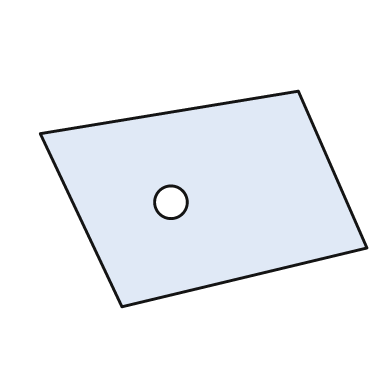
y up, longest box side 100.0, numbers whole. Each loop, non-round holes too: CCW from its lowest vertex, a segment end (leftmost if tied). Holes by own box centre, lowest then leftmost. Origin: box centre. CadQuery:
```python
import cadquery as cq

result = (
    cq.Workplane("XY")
    .moveTo(-25.0, -33.0)
    .lineTo(50.0, -15.0)
    .lineTo(29.0, 33.0)
    .lineTo(-50.0, 20.0)
    .close()
    .moveTo(-10.0, -1.0)
    .circle(5.0)
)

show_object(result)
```